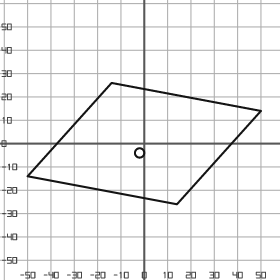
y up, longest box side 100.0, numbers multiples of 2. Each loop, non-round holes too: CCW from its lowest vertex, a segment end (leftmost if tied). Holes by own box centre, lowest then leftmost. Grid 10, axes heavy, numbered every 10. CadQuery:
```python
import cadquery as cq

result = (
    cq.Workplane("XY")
    .moveTo(14.0, -26.0)
    .lineTo(50.0, 14.0)
    .lineTo(-14.0, 26.0)
    .lineTo(-50.0, -14.0)
    .close()
    .moveTo(-2.0, -4.0)
    .circle(2.0)
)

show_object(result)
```